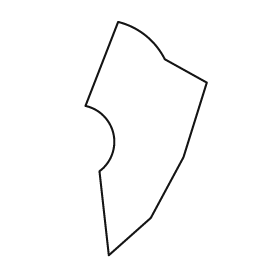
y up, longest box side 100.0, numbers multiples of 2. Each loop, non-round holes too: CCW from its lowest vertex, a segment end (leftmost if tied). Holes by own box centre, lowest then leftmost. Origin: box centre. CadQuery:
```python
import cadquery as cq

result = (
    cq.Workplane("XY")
    .moveTo(-16.0, -50.0)
    .lineTo(2.0, -34.0)
    .lineTo(16.0, -8.0)
    .lineTo(26.0, 24.0)
    .lineTo(8.0, 34.0)
    .threePointArc((0.0, 44.0), (-12.0, 50.0))
    .lineTo(-26.0, 14.0)
    .threePointArc((-14.0, 2.0), (-20.0, -14.0))
    .close()
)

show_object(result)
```